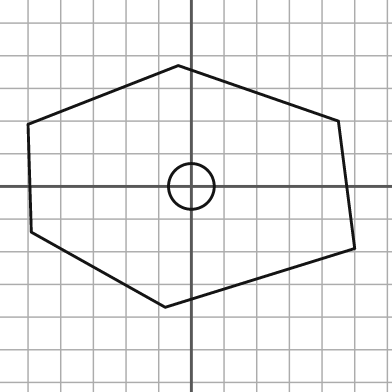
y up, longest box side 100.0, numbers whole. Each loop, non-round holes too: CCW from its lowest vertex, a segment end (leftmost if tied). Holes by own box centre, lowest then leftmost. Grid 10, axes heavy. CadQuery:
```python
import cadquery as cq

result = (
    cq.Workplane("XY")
    .moveTo(-8.0, -37.0)
    .lineTo(50.0, -19.0)
    .lineTo(45.0, 20.0)
    .lineTo(-4.0, 37.0)
    .lineTo(-50.0, 19.0)
    .lineTo(-49.0, -14.0)
    .close()
    .moveTo(0.0, 0.0)
    .circle(7.0)
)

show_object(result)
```